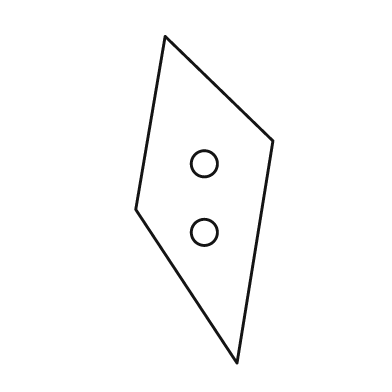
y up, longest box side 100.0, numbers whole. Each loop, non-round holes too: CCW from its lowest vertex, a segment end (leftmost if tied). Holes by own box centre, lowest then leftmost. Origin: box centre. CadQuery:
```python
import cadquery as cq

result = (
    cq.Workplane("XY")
    .moveTo(10.0, -50.0)
    .lineTo(21.0, 18.0)
    .lineTo(-12.0, 50.0)
    .lineTo(-21.0, -3.0)
    .close()
    .moveTo(0.0, -10.0)
    .circle(4.0)
    .moveTo(0.0, 11.0)
    .circle(4.0)
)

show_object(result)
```